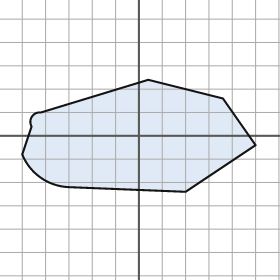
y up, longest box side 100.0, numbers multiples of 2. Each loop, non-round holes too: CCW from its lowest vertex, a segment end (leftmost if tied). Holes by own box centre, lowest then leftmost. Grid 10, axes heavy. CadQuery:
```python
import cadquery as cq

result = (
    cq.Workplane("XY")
    .moveTo(20.0, -24.0)
    .lineTo(50.0, -4.0)
    .lineTo(36.0, 16.0)
    .lineTo(4.0, 24.0)
    .lineTo(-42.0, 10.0)
    .threePointArc((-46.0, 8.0), (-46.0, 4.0))
    .lineTo(-50.0, -8.0)
    .threePointArc((-42.0, -18.0), (-30.0, -22.0))
    .close()
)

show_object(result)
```